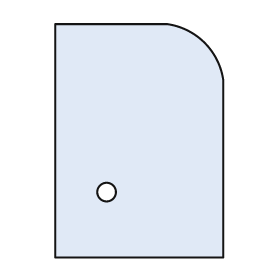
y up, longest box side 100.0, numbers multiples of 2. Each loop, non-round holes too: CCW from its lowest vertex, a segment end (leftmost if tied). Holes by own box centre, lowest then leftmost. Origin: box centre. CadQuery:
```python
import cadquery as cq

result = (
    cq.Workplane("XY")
    .moveTo(-36.0, -50.0)
    .lineTo(36.0, -50.0)
    .lineTo(36.0, 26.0)
    .threePointArc((28.0, 42.0), (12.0, 50.0))
    .lineTo(-36.0, 50.0)
    .close()
    .moveTo(-14.0, -22.0)
    .circle(4.0)
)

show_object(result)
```